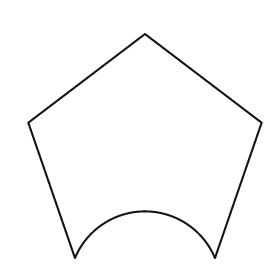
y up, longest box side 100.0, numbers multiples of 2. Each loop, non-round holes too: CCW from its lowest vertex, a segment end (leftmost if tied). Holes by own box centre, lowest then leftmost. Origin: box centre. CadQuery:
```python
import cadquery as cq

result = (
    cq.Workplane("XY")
    .moveTo(-30.0, -48.0)
    .threePointArc((0.0, -28.0), (30.0, -48.0))
    .lineTo(50.0, 10.0)
    .lineTo(0.0, 48.0)
    .lineTo(-50.0, 10.0)
    .close()
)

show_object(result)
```